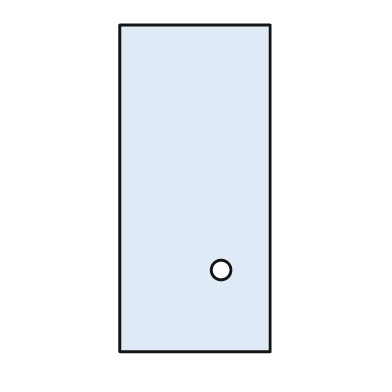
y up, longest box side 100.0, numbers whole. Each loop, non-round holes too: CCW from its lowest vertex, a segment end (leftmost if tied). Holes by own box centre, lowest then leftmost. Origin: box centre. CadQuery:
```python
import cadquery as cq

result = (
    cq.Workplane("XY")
    .moveTo(-23.0, -50.0)
    .lineTo(23.0, -50.0)
    .lineTo(23.0, 50.0)
    .lineTo(-23.0, 50.0)
    .close()
    .moveTo(8.0, -25.0)
    .circle(3.0)
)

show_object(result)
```